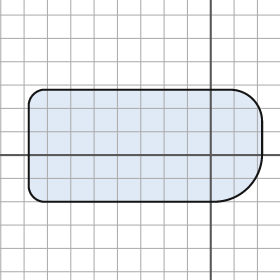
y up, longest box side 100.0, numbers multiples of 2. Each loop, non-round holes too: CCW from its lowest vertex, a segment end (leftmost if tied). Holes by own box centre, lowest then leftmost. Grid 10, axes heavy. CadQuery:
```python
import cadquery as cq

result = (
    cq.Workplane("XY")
    .moveTo(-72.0, -20.0)
    .lineTo(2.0, -20.0)
    .threePointArc((16.0, -14.0), (22.0, 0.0))
    .lineTo(22.0, 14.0)
    .threePointArc((18.0, 24.0), (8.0, 28.0))
    .lineTo(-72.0, 28.0)
    .threePointArc((-76.0, 26.0), (-78.0, 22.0))
    .lineTo(-78.0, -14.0)
    .threePointArc((-76.0, -18.0), (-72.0, -20.0))
    .close()
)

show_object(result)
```